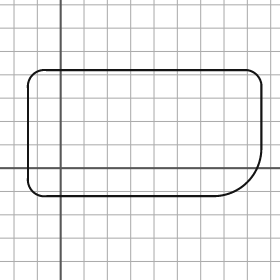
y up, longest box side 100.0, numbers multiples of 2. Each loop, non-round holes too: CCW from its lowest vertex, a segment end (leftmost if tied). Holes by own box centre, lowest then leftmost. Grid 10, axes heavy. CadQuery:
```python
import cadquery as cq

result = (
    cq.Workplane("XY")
    .moveTo(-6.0, -12.0)
    .lineTo(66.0, -12.0)
    .threePointArc((80.0, -6.0), (86.0, 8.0))
    .lineTo(86.0, 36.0)
    .threePointArc((84.0, 40.0), (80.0, 42.0))
    .lineTo(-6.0, 42.0)
    .threePointArc((-12.0, 40.0), (-14.0, 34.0))
    .lineTo(-14.0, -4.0)
    .threePointArc((-12.0, -10.0), (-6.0, -12.0))
    .close()
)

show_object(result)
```